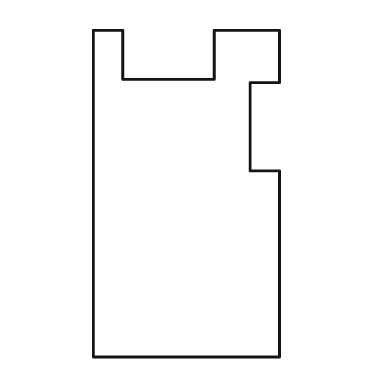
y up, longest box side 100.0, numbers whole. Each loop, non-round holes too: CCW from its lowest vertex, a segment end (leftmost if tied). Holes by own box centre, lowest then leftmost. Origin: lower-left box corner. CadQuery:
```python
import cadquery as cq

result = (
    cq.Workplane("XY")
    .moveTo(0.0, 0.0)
    .lineTo(57.0, 0.0)
    .lineTo(57.0, 57.0)
    .lineTo(48.0, 57.0)
    .lineTo(48.0, 84.0)
    .lineTo(57.0, 84.0)
    .lineTo(57.0, 100.0)
    .lineTo(37.0, 100.0)
    .lineTo(37.0, 85.0)
    .lineTo(9.0, 85.0)
    .lineTo(9.0, 100.0)
    .lineTo(0.0, 100.0)
    .close()
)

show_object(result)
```